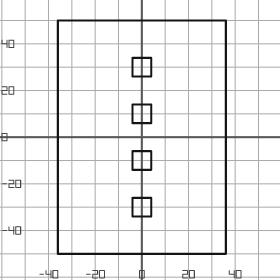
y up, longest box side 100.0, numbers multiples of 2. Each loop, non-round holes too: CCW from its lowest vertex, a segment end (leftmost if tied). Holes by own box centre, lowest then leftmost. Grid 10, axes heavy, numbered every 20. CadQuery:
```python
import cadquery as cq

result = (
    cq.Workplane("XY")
    .moveTo(-36.0, -50.0)
    .lineTo(36.0, -50.0)
    .lineTo(36.0, 50.0)
    .lineTo(-36.0, 50.0)
    .close()
    .moveTo(-4.0, -34.0)
    .lineTo(4.0, -34.0)
    .lineTo(4.0, -26.0)
    .lineTo(-4.0, -26.0)
    .close()
    .moveTo(-4.0, -14.0)
    .lineTo(4.0, -14.0)
    .lineTo(4.0, -6.0)
    .lineTo(-4.0, -6.0)
    .close()
    .moveTo(-4.0, 6.0)
    .lineTo(4.0, 6.0)
    .lineTo(4.0, 14.0)
    .lineTo(-4.0, 14.0)
    .close()
    .moveTo(-4.0, 26.0)
    .lineTo(4.0, 26.0)
    .lineTo(4.0, 34.0)
    .lineTo(-4.0, 34.0)
    .close()
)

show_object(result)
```